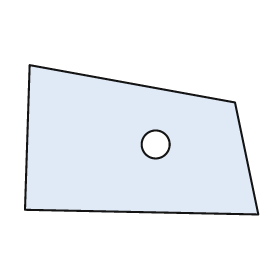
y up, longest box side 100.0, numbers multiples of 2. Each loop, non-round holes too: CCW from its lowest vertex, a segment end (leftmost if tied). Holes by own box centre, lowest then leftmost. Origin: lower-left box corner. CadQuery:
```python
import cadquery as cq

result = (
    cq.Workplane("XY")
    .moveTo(100.0, 0.0)
    .lineTo(90.0, 48.0)
    .lineTo(2.0, 64.0)
    .lineTo(0.0, 2.0)
    .close()
    .moveTo(56.0, 30.0)
    .circle(6.0)
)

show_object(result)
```